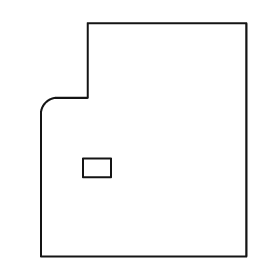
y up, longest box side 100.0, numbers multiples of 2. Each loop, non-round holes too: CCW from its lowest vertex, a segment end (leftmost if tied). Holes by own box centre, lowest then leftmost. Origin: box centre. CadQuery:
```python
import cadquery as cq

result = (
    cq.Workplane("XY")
    .moveTo(-44.0, -50.0)
    .lineTo(44.0, -50.0)
    .lineTo(44.0, 50.0)
    .lineTo(-24.0, 50.0)
    .lineTo(-24.0, 18.0)
    .lineTo(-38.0, 18.0)
    .threePointArc((-42.0, 16.0), (-44.0, 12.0))
    .close()
    .moveTo(-26.0, -16.0)
    .lineTo(-14.0, -16.0)
    .lineTo(-14.0, -8.0)
    .lineTo(-26.0, -8.0)
    .close()
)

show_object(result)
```